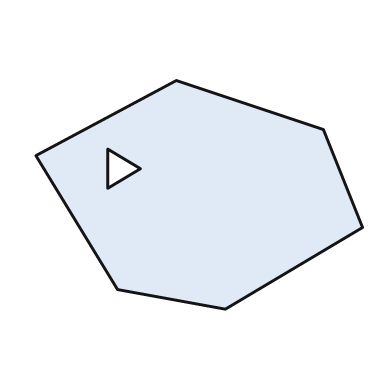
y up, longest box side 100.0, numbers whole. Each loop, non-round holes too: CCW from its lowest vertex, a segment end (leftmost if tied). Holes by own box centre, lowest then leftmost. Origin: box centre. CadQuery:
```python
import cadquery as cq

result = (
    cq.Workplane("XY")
    .moveTo(8.0, -35.0)
    .lineTo(50.0, -10.0)
    .lineTo(38.0, 20.0)
    .lineTo(-7.0, 35.0)
    .lineTo(-50.0, 12.0)
    .lineTo(-25.0, -29.0)
    .close()
    .moveTo(-28.0, 2.0)
    .lineTo(-18.0, 8.0)
    .lineTo(-28.0, 14.0)
    .close()
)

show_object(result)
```